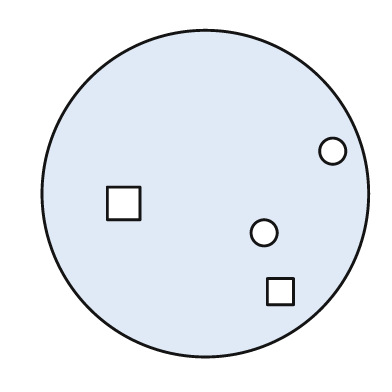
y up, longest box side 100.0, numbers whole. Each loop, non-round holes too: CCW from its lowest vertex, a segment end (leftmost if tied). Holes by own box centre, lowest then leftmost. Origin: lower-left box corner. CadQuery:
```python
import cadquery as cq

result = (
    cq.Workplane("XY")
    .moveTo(50.0, 50.0)
    .circle(50.0)
    .moveTo(69.0, 16.0)
    .lineTo(77.0, 16.0)
    .lineTo(77.0, 24.0)
    .lineTo(69.0, 24.0)
    .close()
    .moveTo(68.0, 38.0)
    .circle(4.0)
    .moveTo(20.0, 42.0)
    .lineTo(30.0, 42.0)
    .lineTo(30.0, 52.0)
    .lineTo(20.0, 52.0)
    .close()
    .moveTo(89.0, 63.0)
    .circle(4.0)
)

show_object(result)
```